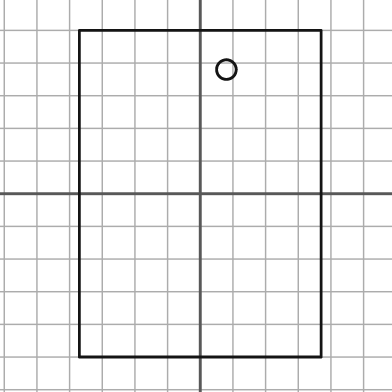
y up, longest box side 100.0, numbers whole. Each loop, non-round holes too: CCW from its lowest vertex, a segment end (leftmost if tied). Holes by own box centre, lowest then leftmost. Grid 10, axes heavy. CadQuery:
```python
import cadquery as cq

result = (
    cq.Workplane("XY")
    .moveTo(-37.0, -50.0)
    .lineTo(37.0, -50.0)
    .lineTo(37.0, 50.0)
    .lineTo(-37.0, 50.0)
    .close()
    .moveTo(8.0, 38.0)
    .circle(3.0)
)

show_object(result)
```